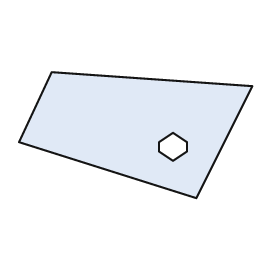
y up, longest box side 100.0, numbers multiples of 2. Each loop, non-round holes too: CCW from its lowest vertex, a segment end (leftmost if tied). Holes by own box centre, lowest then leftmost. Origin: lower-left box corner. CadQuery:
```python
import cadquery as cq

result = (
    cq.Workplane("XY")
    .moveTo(76.0, 0.0)
    .lineTo(100.0, 48.0)
    .lineTo(14.0, 54.0)
    .lineTo(0.0, 24.0)
    .close()
    .moveTo(66.0, 16.0)
    .lineTo(72.0, 20.0)
    .lineTo(72.0, 24.0)
    .lineTo(66.0, 28.0)
    .lineTo(60.0, 24.0)
    .lineTo(60.0, 20.0)
    .close()
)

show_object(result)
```